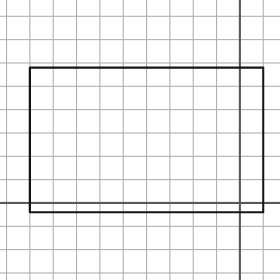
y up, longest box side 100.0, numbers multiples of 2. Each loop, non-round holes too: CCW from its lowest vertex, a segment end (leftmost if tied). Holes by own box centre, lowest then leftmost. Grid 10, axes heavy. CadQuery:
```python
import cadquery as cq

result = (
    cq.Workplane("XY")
    .moveTo(-90.0, -4.0)
    .lineTo(10.0, -4.0)
    .lineTo(10.0, 58.0)
    .lineTo(-90.0, 58.0)
    .close()
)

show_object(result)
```